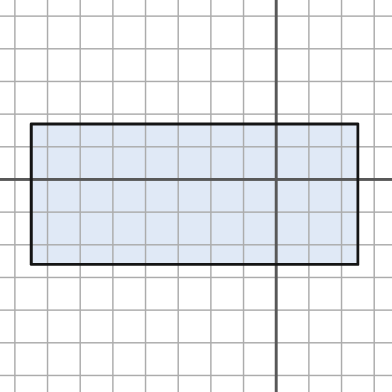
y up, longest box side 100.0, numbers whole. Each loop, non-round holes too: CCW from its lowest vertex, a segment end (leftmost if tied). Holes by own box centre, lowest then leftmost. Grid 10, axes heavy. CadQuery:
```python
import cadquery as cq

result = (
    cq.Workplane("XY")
    .moveTo(-75.0, -26.0)
    .lineTo(25.0, -26.0)
    .lineTo(25.0, 17.0)
    .lineTo(-75.0, 17.0)
    .close()
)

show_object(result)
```